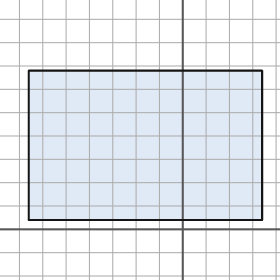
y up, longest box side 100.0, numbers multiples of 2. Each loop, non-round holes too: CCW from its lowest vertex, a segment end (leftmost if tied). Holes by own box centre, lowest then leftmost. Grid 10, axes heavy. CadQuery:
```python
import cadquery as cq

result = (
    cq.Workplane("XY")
    .moveTo(-66.0, 4.0)
    .lineTo(34.0, 4.0)
    .lineTo(34.0, 68.0)
    .lineTo(-66.0, 68.0)
    .close()
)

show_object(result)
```